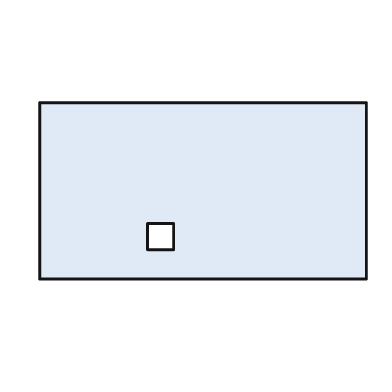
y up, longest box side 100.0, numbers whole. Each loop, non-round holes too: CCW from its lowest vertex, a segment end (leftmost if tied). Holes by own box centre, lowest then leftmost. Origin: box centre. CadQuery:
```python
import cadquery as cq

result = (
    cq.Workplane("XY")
    .moveTo(-50.0, -27.0)
    .lineTo(50.0, -27.0)
    .lineTo(50.0, 27.0)
    .lineTo(-50.0, 27.0)
    .close()
    .moveTo(-17.0, -18.0)
    .lineTo(-9.0, -18.0)
    .lineTo(-9.0, -10.0)
    .lineTo(-17.0, -10.0)
    .close()
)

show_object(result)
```